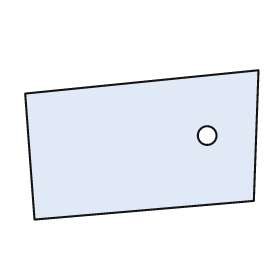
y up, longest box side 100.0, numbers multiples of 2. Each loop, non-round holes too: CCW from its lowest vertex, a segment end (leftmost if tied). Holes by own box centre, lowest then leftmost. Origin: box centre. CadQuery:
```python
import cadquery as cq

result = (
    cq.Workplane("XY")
    .moveTo(-46.0, -32.0)
    .lineTo(48.0, -24.0)
    .lineTo(50.0, 32.0)
    .lineTo(-50.0, 22.0)
    .close()
    .moveTo(28.0, 4.0)
    .circle(4.0)
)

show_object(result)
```